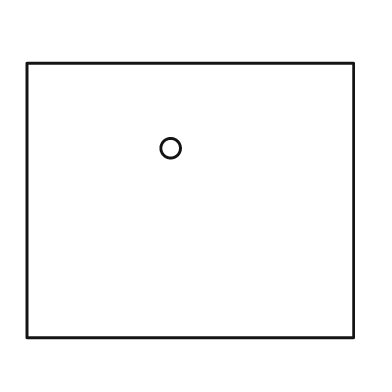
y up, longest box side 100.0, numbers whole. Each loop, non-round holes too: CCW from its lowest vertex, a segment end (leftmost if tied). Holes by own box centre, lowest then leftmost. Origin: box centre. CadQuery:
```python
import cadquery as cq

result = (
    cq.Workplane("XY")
    .moveTo(-50.0, -42.0)
    .lineTo(50.0, -42.0)
    .lineTo(50.0, 42.0)
    .lineTo(-50.0, 42.0)
    .close()
    .moveTo(-6.0, 16.0)
    .circle(3.0)
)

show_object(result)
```